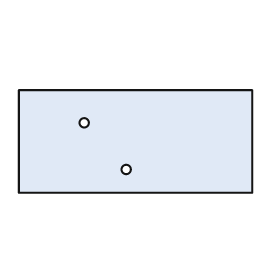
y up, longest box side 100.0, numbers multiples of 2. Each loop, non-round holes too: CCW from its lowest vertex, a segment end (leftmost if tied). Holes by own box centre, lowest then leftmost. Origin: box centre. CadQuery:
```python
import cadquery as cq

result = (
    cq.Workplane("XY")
    .moveTo(-50.0, -22.0)
    .lineTo(50.0, -22.0)
    .lineTo(50.0, 22.0)
    .lineTo(-50.0, 22.0)
    .close()
    .moveTo(-4.0, -12.0)
    .circle(2.0)
    .moveTo(-22.0, 8.0)
    .circle(2.0)
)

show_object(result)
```